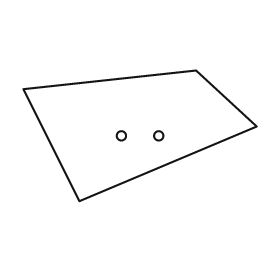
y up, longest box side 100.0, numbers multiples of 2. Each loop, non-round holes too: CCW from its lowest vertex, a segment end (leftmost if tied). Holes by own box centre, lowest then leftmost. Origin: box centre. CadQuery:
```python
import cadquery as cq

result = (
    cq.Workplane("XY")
    .moveTo(-26.0, -28.0)
    .lineTo(50.0, 4.0)
    .lineTo(24.0, 28.0)
    .lineTo(-50.0, 20.0)
    .close()
    .moveTo(-8.0, 0.0)
    .circle(2.0)
    .moveTo(8.0, 0.0)
    .circle(2.0)
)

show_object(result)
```